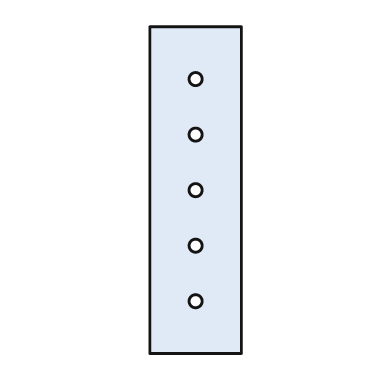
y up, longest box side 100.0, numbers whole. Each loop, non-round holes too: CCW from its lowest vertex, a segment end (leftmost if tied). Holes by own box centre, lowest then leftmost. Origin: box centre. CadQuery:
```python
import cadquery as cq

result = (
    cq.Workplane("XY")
    .moveTo(-14.0, -50.0)
    .lineTo(14.0, -50.0)
    .lineTo(14.0, 50.0)
    .lineTo(-14.0, 50.0)
    .close()
    .moveTo(0.0, -34.0)
    .circle(2.0)
    .moveTo(0.0, -17.0)
    .circle(2.0)
    .moveTo(0.0, 0.0)
    .circle(2.0)
    .moveTo(0.0, 17.0)
    .circle(2.0)
    .moveTo(0.0, 34.0)
    .circle(2.0)
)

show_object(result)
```